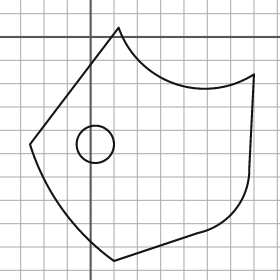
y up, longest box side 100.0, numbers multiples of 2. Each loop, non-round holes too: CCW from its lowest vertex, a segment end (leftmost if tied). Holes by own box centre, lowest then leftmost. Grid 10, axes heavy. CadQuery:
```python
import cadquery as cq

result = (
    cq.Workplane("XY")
    .moveTo(10.0, -96.0)
    .lineTo(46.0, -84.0)
    .threePointArc((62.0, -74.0), (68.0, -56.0))
    .lineTo(70.0, -16.0)
    .threePointArc((36.0, -20.0), (12.0, 4.0))
    .lineTo(-26.0, -46.0)
    .threePointArc((-12.0, -74.0), (10.0, -96.0))
    .close()
    .moveTo(2.0, -46.0)
    .circle(8.0)
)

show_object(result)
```